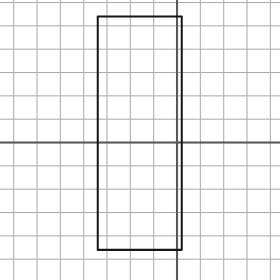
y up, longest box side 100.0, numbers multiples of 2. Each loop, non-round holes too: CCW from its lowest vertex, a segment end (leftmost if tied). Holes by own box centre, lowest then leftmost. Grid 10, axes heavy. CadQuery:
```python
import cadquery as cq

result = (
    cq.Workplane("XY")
    .moveTo(-34.0, -46.0)
    .lineTo(2.0, -46.0)
    .lineTo(2.0, 54.0)
    .lineTo(-34.0, 54.0)
    .close()
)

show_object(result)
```